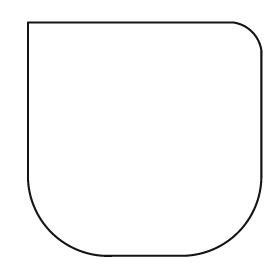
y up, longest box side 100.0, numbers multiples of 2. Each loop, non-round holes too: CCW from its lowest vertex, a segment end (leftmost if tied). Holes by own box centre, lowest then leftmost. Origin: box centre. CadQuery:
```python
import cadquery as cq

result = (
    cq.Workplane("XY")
    .moveTo(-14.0, -50.0)
    .lineTo(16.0, -50.0)
    .threePointArc((40.0, -40.0), (50.0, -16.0))
    .lineTo(50.0, 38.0)
    .threePointArc((46.0, 46.0), (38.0, 50.0))
    .lineTo(-50.0, 50.0)
    .lineTo(-50.0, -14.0)
    .threePointArc((-40.0, -40.0), (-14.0, -50.0))
    .close()
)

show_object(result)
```